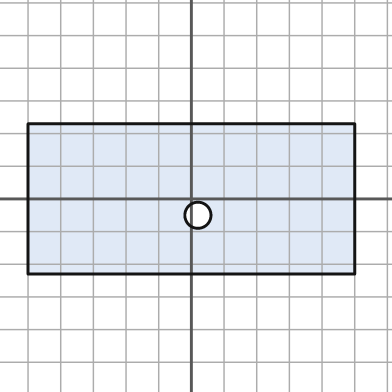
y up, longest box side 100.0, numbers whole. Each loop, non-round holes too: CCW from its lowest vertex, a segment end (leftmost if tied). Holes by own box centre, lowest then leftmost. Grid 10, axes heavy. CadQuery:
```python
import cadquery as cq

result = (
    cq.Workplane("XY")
    .moveTo(-50.0, -23.0)
    .lineTo(50.0, -23.0)
    .lineTo(50.0, 23.0)
    .lineTo(-50.0, 23.0)
    .close()
    .moveTo(2.0, -5.0)
    .circle(4.0)
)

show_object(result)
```